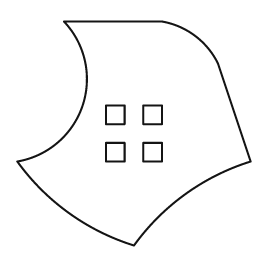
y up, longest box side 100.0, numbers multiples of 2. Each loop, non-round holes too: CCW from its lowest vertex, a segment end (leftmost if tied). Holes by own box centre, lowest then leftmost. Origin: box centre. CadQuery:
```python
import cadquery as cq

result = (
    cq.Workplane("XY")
    .moveTo(0.0, -48.0)
    .threePointArc((22.0, -26.0), (50.0, -12.0))
    .lineTo(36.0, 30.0)
    .threePointArc((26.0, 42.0), (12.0, 48.0))
    .lineTo(-30.0, 48.0)
    .threePointArc((-22.0, 12.0), (-50.0, -12.0))
    .threePointArc((-28.0, -34.0), (0.0, -48.0))
    .close()
    .moveTo(-12.0, -12.0)
    .lineTo(-4.0, -12.0)
    .lineTo(-4.0, -4.0)
    .lineTo(-12.0, -4.0)
    .close()
    .moveTo(4.0, -12.0)
    .lineTo(12.0, -12.0)
    .lineTo(12.0, -4.0)
    .lineTo(4.0, -4.0)
    .close()
    .moveTo(-12.0, 4.0)
    .lineTo(-4.0, 4.0)
    .lineTo(-4.0, 12.0)
    .lineTo(-12.0, 12.0)
    .close()
    .moveTo(4.0, 4.0)
    .lineTo(12.0, 4.0)
    .lineTo(12.0, 12.0)
    .lineTo(4.0, 12.0)
    .close()
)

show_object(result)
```